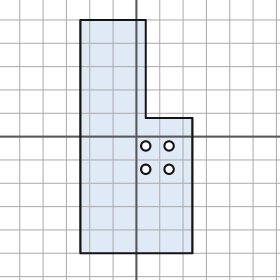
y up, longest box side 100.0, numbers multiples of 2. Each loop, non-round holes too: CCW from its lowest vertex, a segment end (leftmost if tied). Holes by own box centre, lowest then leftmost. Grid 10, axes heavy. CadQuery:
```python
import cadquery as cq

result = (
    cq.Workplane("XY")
    .moveTo(-24.0, -50.0)
    .lineTo(24.0, -50.0)
    .lineTo(24.0, 8.0)
    .lineTo(4.0, 8.0)
    .lineTo(4.0, 50.0)
    .lineTo(-24.0, 50.0)
    .close()
    .moveTo(4.0, -14.0)
    .circle(2.0)
    .moveTo(14.0, -14.0)
    .circle(2.0)
    .moveTo(4.0, -4.0)
    .circle(2.0)
    .moveTo(14.0, -4.0)
    .circle(2.0)
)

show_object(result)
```